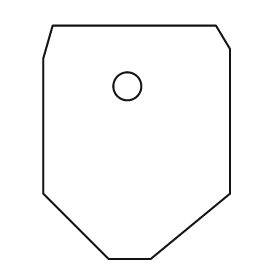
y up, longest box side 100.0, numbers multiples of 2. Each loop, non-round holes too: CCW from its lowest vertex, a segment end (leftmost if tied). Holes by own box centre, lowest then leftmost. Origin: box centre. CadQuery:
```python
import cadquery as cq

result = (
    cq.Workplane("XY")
    .moveTo(-12.0, -50.0)
    .lineTo(6.0, -50.0)
    .lineTo(40.0, -22.0)
    .lineTo(40.0, 40.0)
    .lineTo(34.0, 50.0)
    .lineTo(-36.0, 50.0)
    .lineTo(-40.0, 36.0)
    .lineTo(-40.0, -22.0)
    .close()
    .moveTo(-4.0, 24.0)
    .circle(6.0)
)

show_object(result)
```